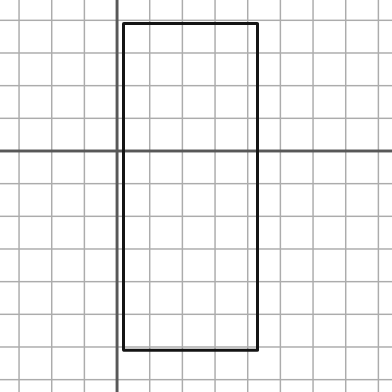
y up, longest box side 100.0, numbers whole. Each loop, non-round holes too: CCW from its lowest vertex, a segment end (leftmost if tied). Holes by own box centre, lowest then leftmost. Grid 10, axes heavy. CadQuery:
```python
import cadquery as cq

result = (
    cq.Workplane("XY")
    .moveTo(2.0, -61.0)
    .lineTo(43.0, -61.0)
    .lineTo(43.0, 39.0)
    .lineTo(2.0, 39.0)
    .close()
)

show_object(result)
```